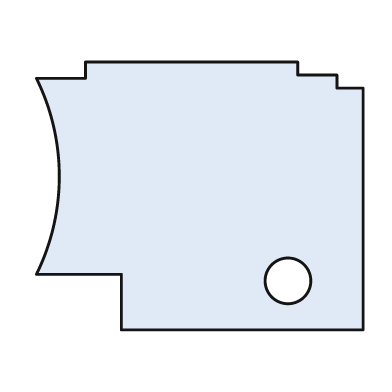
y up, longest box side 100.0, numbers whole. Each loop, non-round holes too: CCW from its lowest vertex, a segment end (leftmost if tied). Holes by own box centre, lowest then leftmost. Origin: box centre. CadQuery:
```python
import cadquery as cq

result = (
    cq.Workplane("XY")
    .moveTo(-24.0, -41.0)
    .lineTo(50.0, -41.0)
    .lineTo(50.0, 33.0)
    .lineTo(42.0, 33.0)
    .lineTo(42.0, 37.0)
    .lineTo(30.0, 37.0)
    .lineTo(30.0, 41.0)
    .lineTo(-35.0, 41.0)
    .lineTo(-35.0, 36.0)
    .lineTo(-50.0, 36.0)
    .threePointArc((-43.0, 6.0), (-50.0, -24.0))
    .lineTo(-24.0, -24.0)
    .close()
    .moveTo(27.0, -26.0)
    .circle(7.0)
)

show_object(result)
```